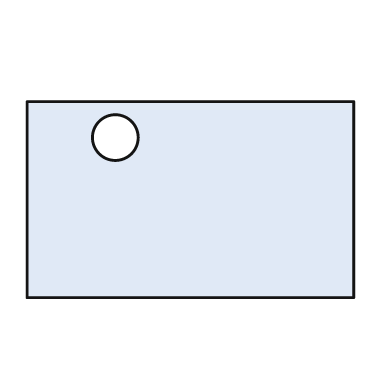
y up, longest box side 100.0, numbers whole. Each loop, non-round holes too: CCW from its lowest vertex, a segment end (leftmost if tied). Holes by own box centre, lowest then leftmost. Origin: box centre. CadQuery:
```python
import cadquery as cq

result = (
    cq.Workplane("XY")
    .moveTo(-50.0, -30.0)
    .lineTo(50.0, -30.0)
    .lineTo(50.0, 30.0)
    .lineTo(-50.0, 30.0)
    .close()
    .moveTo(-23.0, 19.0)
    .circle(7.0)
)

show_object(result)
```